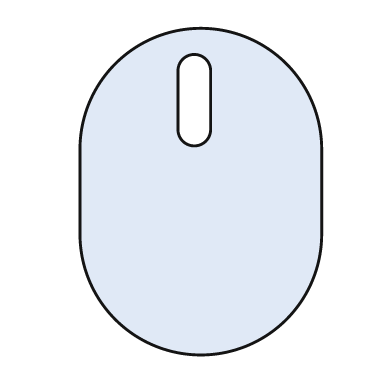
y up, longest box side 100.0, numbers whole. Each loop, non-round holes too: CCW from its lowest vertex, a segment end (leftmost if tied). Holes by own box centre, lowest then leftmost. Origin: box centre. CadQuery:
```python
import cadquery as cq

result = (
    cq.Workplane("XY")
    .moveTo(-37.0, -13.0)
    .threePointArc((0.0, -50.0), (37.0, -13.0))
    .lineTo(37.0, 13.0)
    .threePointArc((0.0, 50.0), (-37.0, 13.0))
    .close()
    .moveTo(-7.0, 19.0)
    .threePointArc((-2.0, 14.0), (3.0, 19.0))
    .lineTo(3.0, 37.0)
    .threePointArc((-2.0, 42.0), (-7.0, 37.0))
    .close()
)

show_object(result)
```